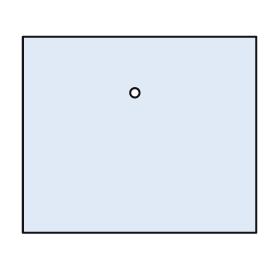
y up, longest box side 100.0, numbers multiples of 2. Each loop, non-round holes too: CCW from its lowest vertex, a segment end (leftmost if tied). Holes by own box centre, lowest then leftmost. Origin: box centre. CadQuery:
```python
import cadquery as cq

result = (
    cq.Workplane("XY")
    .moveTo(-50.0, -42.0)
    .lineTo(50.0, -42.0)
    .lineTo(50.0, 42.0)
    .lineTo(-50.0, 42.0)
    .close()
    .moveTo(-2.0, 18.0)
    .circle(2.0)
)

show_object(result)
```